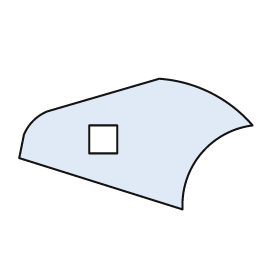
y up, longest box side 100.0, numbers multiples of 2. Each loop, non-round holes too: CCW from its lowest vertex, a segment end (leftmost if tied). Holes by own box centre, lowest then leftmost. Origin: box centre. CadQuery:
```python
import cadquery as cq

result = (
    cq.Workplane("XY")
    .moveTo(20.0, -28.0)
    .threePointArc((28.0, -4.0), (50.0, 8.0))
    .threePointArc((32.0, 22.0), (10.0, 28.0))
    .lineTo(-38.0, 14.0)
    .threePointArc((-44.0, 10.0), (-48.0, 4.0))
    .lineTo(-50.0, -6.0)
    .close()
    .moveTo(-20.0, -4.0)
    .lineTo(-8.0, -4.0)
    .lineTo(-8.0, 8.0)
    .lineTo(-20.0, 8.0)
    .close()
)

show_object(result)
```